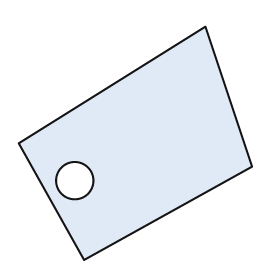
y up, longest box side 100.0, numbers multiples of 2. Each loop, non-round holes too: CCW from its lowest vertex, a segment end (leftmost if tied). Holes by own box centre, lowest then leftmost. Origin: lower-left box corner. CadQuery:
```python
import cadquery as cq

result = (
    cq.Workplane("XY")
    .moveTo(28.0, 0.0)
    .lineTo(100.0, 40.0)
    .lineTo(80.0, 100.0)
    .lineTo(0.0, 50.0)
    .close()
    .moveTo(24.0, 34.0)
    .circle(8.0)
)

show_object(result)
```